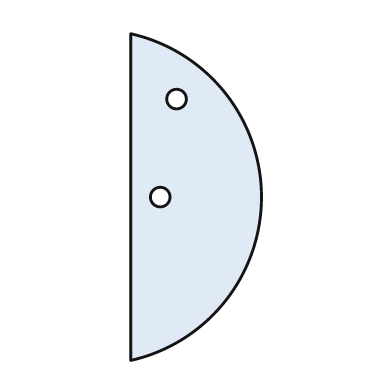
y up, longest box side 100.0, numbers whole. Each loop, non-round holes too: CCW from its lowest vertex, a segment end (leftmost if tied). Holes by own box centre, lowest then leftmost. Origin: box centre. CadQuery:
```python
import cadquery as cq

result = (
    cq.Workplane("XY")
    .moveTo(-20.0, -50.0)
    .threePointArc((20.0, 0.0), (-20.0, 50.0))
    .close()
    .moveTo(-11.0, 0.0)
    .circle(3.0)
    .moveTo(-6.0, 30.0)
    .circle(3.0)
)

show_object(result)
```